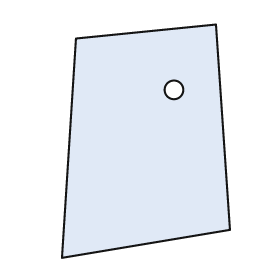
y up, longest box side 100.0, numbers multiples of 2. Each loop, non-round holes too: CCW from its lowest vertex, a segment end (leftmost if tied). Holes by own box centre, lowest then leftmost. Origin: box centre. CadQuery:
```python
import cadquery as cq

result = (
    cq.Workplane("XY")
    .moveTo(-36.0, -50.0)
    .lineTo(36.0, -38.0)
    .lineTo(30.0, 50.0)
    .lineTo(-30.0, 44.0)
    .close()
    .moveTo(12.0, 22.0)
    .circle(4.0)
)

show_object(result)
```